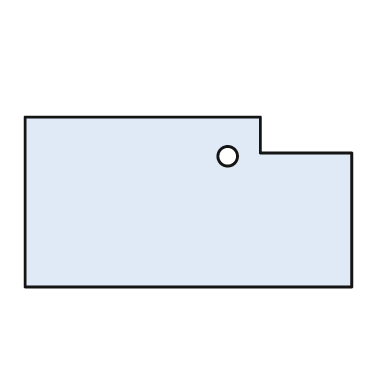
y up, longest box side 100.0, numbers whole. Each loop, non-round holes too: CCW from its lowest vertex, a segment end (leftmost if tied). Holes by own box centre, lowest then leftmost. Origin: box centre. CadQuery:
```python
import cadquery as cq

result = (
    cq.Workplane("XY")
    .moveTo(-50.0, -26.0)
    .lineTo(50.0, -26.0)
    .lineTo(50.0, 15.0)
    .lineTo(22.0, 15.0)
    .lineTo(22.0, 26.0)
    .lineTo(-50.0, 26.0)
    .close()
    .moveTo(12.0, 14.0)
    .circle(3.0)
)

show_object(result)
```